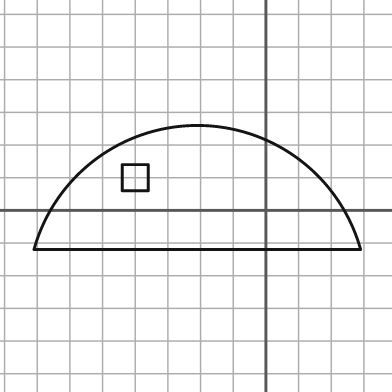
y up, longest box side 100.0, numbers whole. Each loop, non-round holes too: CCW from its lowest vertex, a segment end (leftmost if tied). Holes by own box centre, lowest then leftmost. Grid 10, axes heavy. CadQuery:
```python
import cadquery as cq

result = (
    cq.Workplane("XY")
    .moveTo(-71.0, -12.0)
    .lineTo(29.0, -12.0)
    .threePointArc((-21.0, 26.0), (-71.0, -12.0))
    .close()
    .moveTo(-44.0, 6.0)
    .lineTo(-36.0, 6.0)
    .lineTo(-36.0, 14.0)
    .lineTo(-44.0, 14.0)
    .close()
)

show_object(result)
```